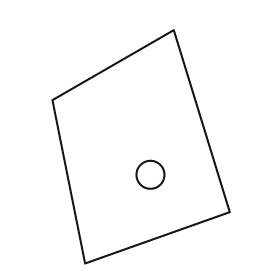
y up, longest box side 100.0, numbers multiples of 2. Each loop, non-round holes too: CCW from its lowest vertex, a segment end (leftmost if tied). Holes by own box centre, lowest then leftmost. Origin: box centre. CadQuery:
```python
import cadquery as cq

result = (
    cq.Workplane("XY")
    .moveTo(-24.0, -50.0)
    .lineTo(38.0, -28.0)
    .lineTo(14.0, 50.0)
    .lineTo(-38.0, 20.0)
    .close()
    .moveTo(4.0, -12.0)
    .circle(6.0)
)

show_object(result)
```